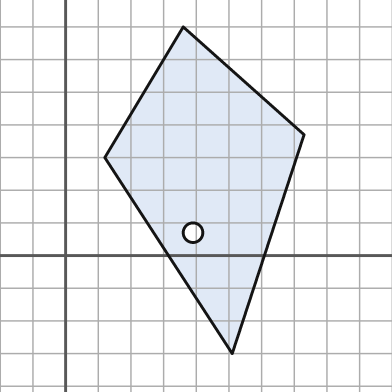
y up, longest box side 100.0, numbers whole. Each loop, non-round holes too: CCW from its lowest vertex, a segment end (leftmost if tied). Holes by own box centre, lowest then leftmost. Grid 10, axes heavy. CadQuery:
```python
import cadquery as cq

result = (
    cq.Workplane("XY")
    .moveTo(51.0, -30.0)
    .lineTo(73.0, 37.0)
    .lineTo(36.0, 70.0)
    .lineTo(12.0, 30.0)
    .close()
    .moveTo(39.0, 7.0)
    .circle(3.0)
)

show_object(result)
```